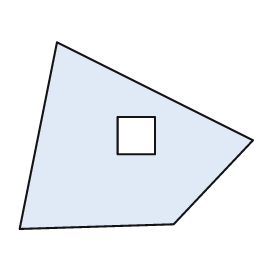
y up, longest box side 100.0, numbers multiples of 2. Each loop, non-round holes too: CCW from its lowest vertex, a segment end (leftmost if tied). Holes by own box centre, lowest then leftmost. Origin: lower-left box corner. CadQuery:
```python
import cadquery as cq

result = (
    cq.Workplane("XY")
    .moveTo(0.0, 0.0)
    .lineTo(66.0, 2.0)
    .lineTo(100.0, 38.0)
    .lineTo(16.0, 80.0)
    .close()
    .moveTo(42.0, 32.0)
    .lineTo(58.0, 32.0)
    .lineTo(58.0, 48.0)
    .lineTo(42.0, 48.0)
    .close()
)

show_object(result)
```